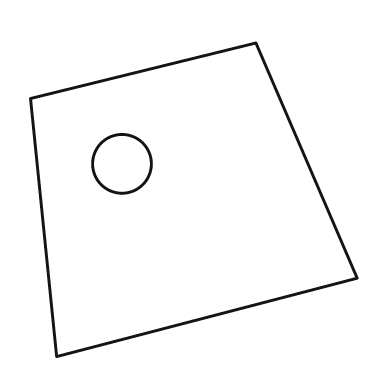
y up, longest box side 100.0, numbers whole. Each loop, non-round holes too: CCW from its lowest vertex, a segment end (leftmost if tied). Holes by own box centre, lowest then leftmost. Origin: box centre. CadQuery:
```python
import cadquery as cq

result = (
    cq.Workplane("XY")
    .moveTo(-42.0, -48.0)
    .lineTo(50.0, -24.0)
    .lineTo(19.0, 48.0)
    .lineTo(-50.0, 31.0)
    .close()
    .moveTo(-22.0, 11.0)
    .circle(9.0)
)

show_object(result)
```